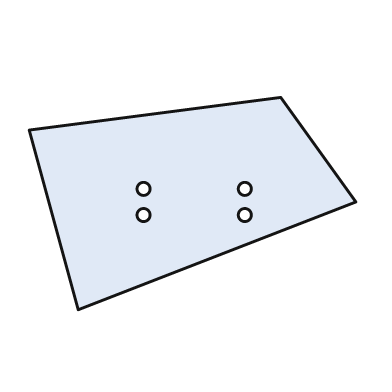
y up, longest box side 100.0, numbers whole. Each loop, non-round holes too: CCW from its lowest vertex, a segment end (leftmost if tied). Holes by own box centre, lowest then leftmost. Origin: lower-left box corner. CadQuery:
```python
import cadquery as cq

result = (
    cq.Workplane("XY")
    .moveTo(15.0, 0.0)
    .lineTo(100.0, 33.0)
    .lineTo(77.0, 65.0)
    .lineTo(0.0, 55.0)
    .close()
    .moveTo(35.0, 29.0)
    .circle(2.0)
    .moveTo(66.0, 29.0)
    .circle(2.0)
    .moveTo(35.0, 37.0)
    .circle(2.0)
    .moveTo(66.0, 37.0)
    .circle(2.0)
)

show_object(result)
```